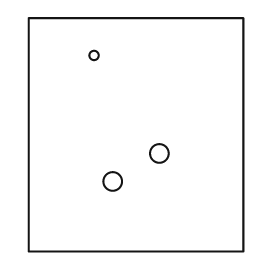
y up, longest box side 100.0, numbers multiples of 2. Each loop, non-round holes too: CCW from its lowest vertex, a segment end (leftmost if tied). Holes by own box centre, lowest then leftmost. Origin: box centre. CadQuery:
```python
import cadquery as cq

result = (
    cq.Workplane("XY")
    .moveTo(-46.0, -50.0)
    .lineTo(46.0, -50.0)
    .lineTo(46.0, 50.0)
    .lineTo(-46.0, 50.0)
    .close()
    .moveTo(-10.0, -20.0)
    .circle(4.0)
    .moveTo(10.0, -8.0)
    .circle(4.0)
    .moveTo(-18.0, 34.0)
    .circle(2.0)
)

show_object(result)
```